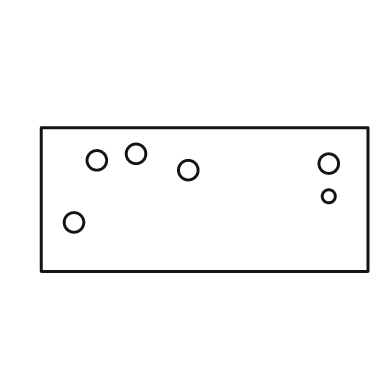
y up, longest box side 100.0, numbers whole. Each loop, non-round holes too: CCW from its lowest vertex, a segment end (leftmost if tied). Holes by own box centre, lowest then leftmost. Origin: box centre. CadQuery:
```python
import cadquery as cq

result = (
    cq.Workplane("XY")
    .moveTo(-50.0, -22.0)
    .lineTo(50.0, -22.0)
    .lineTo(50.0, 22.0)
    .lineTo(-50.0, 22.0)
    .close()
    .moveTo(-40.0, -7.0)
    .circle(3.0)
    .moveTo(38.0, 1.0)
    .circle(2.0)
    .moveTo(-5.0, 9.0)
    .circle(3.0)
    .moveTo(38.0, 11.0)
    .circle(3.0)
    .moveTo(-33.0, 12.0)
    .circle(3.0)
    .moveTo(-21.0, 14.0)
    .circle(3.0)
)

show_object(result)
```